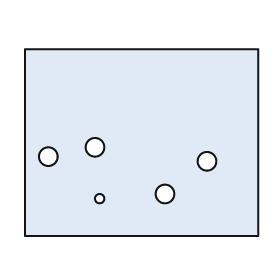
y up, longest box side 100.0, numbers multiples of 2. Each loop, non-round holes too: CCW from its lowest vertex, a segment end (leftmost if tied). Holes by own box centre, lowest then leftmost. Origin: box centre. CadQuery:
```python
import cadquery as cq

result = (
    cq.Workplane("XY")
    .moveTo(-50.0, -40.0)
    .lineTo(50.0, -40.0)
    .lineTo(50.0, 40.0)
    .lineTo(-50.0, 40.0)
    .close()
    .moveTo(-18.0, -24.0)
    .circle(2.0)
    .moveTo(10.0, -22.0)
    .circle(4.0)
    .moveTo(28.0, -8.0)
    .circle(4.0)
    .moveTo(-40.0, -6.0)
    .circle(4.0)
    .moveTo(-20.0, -2.0)
    .circle(4.0)
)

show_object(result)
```